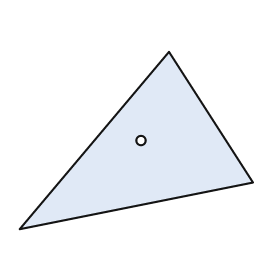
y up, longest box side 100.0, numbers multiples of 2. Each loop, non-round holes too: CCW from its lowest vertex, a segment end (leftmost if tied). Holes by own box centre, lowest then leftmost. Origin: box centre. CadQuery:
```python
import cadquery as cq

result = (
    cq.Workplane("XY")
    .moveTo(-50.0, -38.0)
    .lineTo(50.0, -18.0)
    .lineTo(14.0, 38.0)
    .close()
    .moveTo(2.0, 0.0)
    .circle(2.0)
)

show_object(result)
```